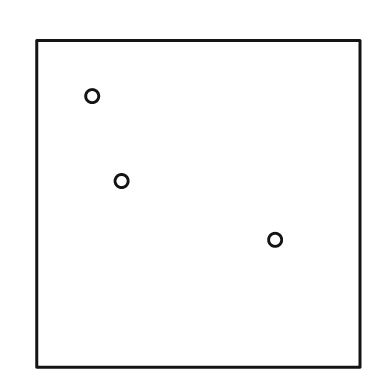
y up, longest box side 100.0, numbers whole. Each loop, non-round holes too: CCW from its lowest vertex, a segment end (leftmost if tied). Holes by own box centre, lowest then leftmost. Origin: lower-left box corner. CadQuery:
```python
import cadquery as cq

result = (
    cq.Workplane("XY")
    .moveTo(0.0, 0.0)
    .lineTo(99.0, 0.0)
    .lineTo(99.0, 100.0)
    .lineTo(0.0, 100.0)
    .close()
    .moveTo(73.0, 39.0)
    .circle(2.0)
    .moveTo(26.0, 57.0)
    .circle(2.0)
    .moveTo(17.0, 83.0)
    .circle(2.0)
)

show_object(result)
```